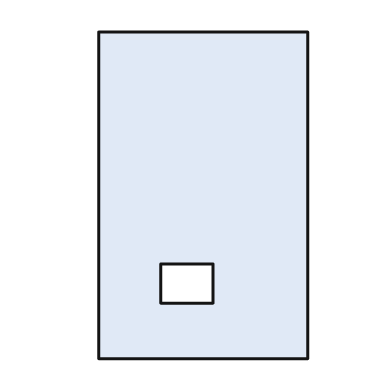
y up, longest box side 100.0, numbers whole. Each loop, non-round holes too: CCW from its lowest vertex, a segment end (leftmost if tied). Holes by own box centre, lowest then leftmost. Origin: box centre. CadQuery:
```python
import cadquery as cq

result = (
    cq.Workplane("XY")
    .moveTo(-32.0, -50.0)
    .lineTo(32.0, -50.0)
    .lineTo(32.0, 50.0)
    .lineTo(-32.0, 50.0)
    .close()
    .moveTo(-13.0, -33.0)
    .lineTo(3.0, -33.0)
    .lineTo(3.0, -21.0)
    .lineTo(-13.0, -21.0)
    .close()
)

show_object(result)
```